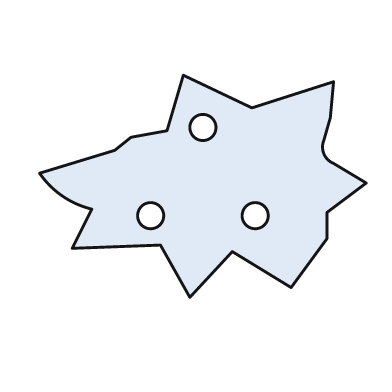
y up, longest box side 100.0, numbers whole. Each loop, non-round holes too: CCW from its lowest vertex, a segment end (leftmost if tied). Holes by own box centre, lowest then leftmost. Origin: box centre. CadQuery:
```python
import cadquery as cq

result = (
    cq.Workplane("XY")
    .moveTo(-4.0, -34.0)
    .lineTo(9.0, -20.0)
    .lineTo(27.0, -31.0)
    .lineTo(38.0, -16.0)
    .lineTo(38.0, -8.0)
    .lineTo(50.0, 1.0)
    .lineTo(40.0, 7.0)
    .threePointArc((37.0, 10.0), (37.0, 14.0))
    .lineTo(39.0, 21.0)
    .lineTo(40.0, 32.0)
    .lineTo(15.0, 24.0)
    .lineTo(-6.0, 34.0)
    .lineTo(-11.0, 17.0)
    .lineTo(-22.0, 15.0)
    .lineTo(-27.0, 11.0)
    .lineTo(-50.0, 4.0)
    .threePointArc((-43.0, -3.0), (-34.0, -7.0))
    .lineTo(-40.0, -19.0)
    .lineTo(-13.0, -18.0)
    .close()
    .moveTo(-16.0, -9.0)
    .circle(4.0)
    .moveTo(16.0, -9.0)
    .circle(4.0)
    .moveTo(0.0, 18.0)
    .circle(4.0)
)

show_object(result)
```